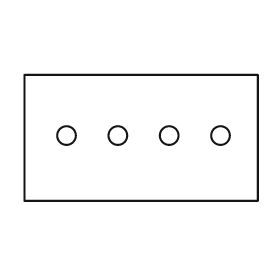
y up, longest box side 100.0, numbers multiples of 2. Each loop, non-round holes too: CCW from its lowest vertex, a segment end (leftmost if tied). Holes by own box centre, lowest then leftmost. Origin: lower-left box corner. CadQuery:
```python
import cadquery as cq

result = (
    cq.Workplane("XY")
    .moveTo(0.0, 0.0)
    .lineTo(100.0, 0.0)
    .lineTo(100.0, 54.0)
    .lineTo(0.0, 54.0)
    .close()
    .moveTo(18.0, 28.0)
    .circle(4.0)
    .moveTo(40.0, 28.0)
    .circle(4.0)
    .moveTo(62.0, 28.0)
    .circle(4.0)
    .moveTo(84.0, 28.0)
    .circle(4.0)
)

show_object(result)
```